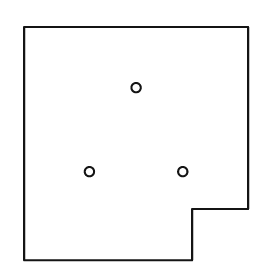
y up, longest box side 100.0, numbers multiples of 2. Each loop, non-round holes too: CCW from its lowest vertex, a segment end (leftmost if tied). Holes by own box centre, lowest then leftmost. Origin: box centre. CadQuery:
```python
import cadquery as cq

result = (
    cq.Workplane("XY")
    .moveTo(-48.0, -50.0)
    .lineTo(24.0, -50.0)
    .lineTo(24.0, -28.0)
    .lineTo(48.0, -28.0)
    .lineTo(48.0, 50.0)
    .lineTo(-48.0, 50.0)
    .close()
    .moveTo(-20.0, -12.0)
    .circle(2.0)
    .moveTo(20.0, -12.0)
    .circle(2.0)
    .moveTo(0.0, 24.0)
    .circle(2.0)
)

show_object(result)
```